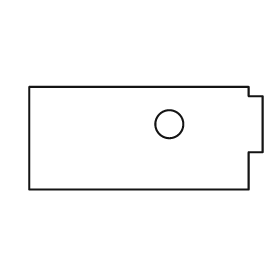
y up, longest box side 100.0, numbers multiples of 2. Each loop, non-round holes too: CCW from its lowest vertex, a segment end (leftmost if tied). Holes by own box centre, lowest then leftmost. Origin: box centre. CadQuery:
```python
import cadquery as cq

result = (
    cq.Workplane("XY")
    .moveTo(-50.0, -22.0)
    .lineTo(44.0, -22.0)
    .lineTo(44.0, -6.0)
    .lineTo(50.0, -6.0)
    .lineTo(50.0, 18.0)
    .lineTo(44.0, 18.0)
    .lineTo(44.0, 22.0)
    .lineTo(-50.0, 22.0)
    .close()
    .moveTo(10.0, 6.0)
    .circle(6.0)
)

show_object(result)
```